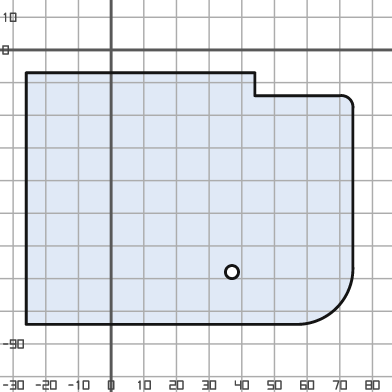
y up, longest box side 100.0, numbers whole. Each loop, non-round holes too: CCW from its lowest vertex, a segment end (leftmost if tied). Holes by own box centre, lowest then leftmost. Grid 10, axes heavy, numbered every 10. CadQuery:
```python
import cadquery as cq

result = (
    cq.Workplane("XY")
    .moveTo(-26.0, -84.0)
    .lineTo(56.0, -84.0)
    .threePointArc((69.0, -79.0), (74.0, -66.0))
    .lineTo(74.0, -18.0)
    .threePointArc((73.0, -15.0), (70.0, -14.0))
    .lineTo(44.0, -14.0)
    .lineTo(44.0, -7.0)
    .lineTo(-26.0, -7.0)
    .close()
    .moveTo(37.0, -68.0)
    .circle(2.0)
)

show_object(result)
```